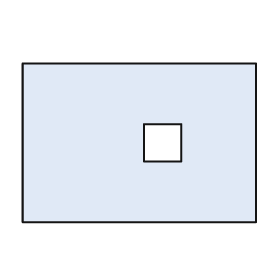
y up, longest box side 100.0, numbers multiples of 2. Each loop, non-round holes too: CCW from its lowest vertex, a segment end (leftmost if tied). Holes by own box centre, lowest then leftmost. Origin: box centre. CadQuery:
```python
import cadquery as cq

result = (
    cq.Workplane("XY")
    .moveTo(-50.0, -34.0)
    .lineTo(50.0, -34.0)
    .lineTo(50.0, 34.0)
    .lineTo(-50.0, 34.0)
    .close()
    .moveTo(2.0, -8.0)
    .lineTo(18.0, -8.0)
    .lineTo(18.0, 8.0)
    .lineTo(2.0, 8.0)
    .close()
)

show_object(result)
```